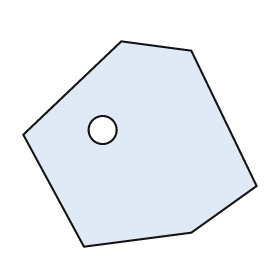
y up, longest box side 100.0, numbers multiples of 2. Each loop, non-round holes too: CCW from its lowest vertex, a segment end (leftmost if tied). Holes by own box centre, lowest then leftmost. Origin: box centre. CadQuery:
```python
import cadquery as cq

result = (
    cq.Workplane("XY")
    .moveTo(-24.0, -44.0)
    .lineTo(22.0, -38.0)
    .lineTo(50.0, -18.0)
    .lineTo(22.0, 40.0)
    .lineTo(-8.0, 44.0)
    .lineTo(-50.0, 4.0)
    .close()
    .moveTo(-16.0, 6.0)
    .circle(6.0)
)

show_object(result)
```